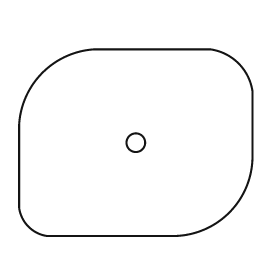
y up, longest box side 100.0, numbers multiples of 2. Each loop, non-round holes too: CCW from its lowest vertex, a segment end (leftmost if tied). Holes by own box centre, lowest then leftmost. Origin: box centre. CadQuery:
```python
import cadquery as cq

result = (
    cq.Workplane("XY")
    .moveTo(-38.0, -40.0)
    .lineTo(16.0, -40.0)
    .threePointArc((40.0, -30.0), (50.0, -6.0))
    .lineTo(50.0, 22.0)
    .threePointArc((44.0, 34.0), (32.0, 40.0))
    .lineTo(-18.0, 40.0)
    .threePointArc((-40.0, 30.0), (-50.0, 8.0))
    .lineTo(-50.0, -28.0)
    .threePointArc((-46.0, -36.0), (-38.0, -40.0))
    .close()
    .moveTo(0.0, 0.0)
    .circle(4.0)
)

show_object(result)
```